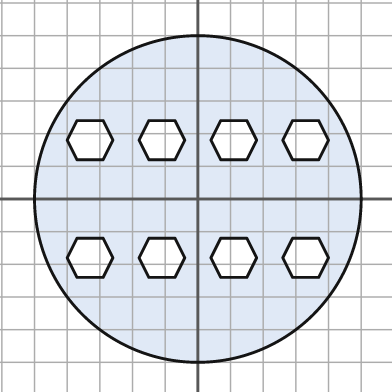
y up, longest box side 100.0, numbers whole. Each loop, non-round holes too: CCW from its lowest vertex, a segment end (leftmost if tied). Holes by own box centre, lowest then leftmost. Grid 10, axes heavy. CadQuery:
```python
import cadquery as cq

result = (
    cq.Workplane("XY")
    .moveTo(0.0, 0.0)
    .circle(50.0)
    .moveTo(-37.0, -24.0)
    .lineTo(-29.0, -24.0)
    .lineTo(-26.0, -18.0)
    .lineTo(-29.0, -12.0)
    .lineTo(-37.0, -12.0)
    .lineTo(-40.0, -18.0)
    .close()
    .moveTo(-15.0, -24.0)
    .lineTo(-7.0, -24.0)
    .lineTo(-4.0, -18.0)
    .lineTo(-7.0, -12.0)
    .lineTo(-15.0, -12.0)
    .lineTo(-18.0, -18.0)
    .close()
    .moveTo(7.0, -24.0)
    .lineTo(15.0, -24.0)
    .lineTo(18.0, -18.0)
    .lineTo(15.0, -12.0)
    .lineTo(7.0, -12.0)
    .lineTo(4.0, -18.0)
    .close()
    .moveTo(29.0, -24.0)
    .lineTo(37.0, -24.0)
    .lineTo(40.0, -18.0)
    .lineTo(37.0, -12.0)
    .lineTo(29.0, -12.0)
    .lineTo(26.0, -18.0)
    .close()
    .moveTo(-37.0, 12.0)
    .lineTo(-29.0, 12.0)
    .lineTo(-26.0, 18.0)
    .lineTo(-29.0, 24.0)
    .lineTo(-37.0, 24.0)
    .lineTo(-40.0, 18.0)
    .close()
    .moveTo(-15.0, 12.0)
    .lineTo(-7.0, 12.0)
    .lineTo(-4.0, 18.0)
    .lineTo(-7.0, 24.0)
    .lineTo(-15.0, 24.0)
    .lineTo(-18.0, 18.0)
    .close()
    .moveTo(7.0, 12.0)
    .lineTo(15.0, 12.0)
    .lineTo(18.0, 18.0)
    .lineTo(15.0, 24.0)
    .lineTo(7.0, 24.0)
    .lineTo(4.0, 18.0)
    .close()
    .moveTo(29.0, 12.0)
    .lineTo(37.0, 12.0)
    .lineTo(40.0, 18.0)
    .lineTo(37.0, 24.0)
    .lineTo(29.0, 24.0)
    .lineTo(26.0, 18.0)
    .close()
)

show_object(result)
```